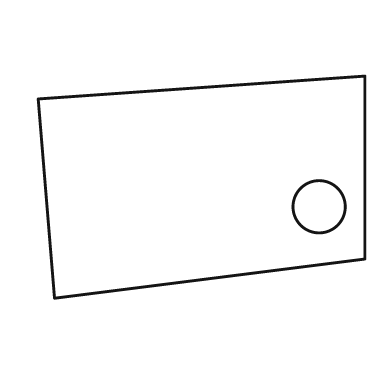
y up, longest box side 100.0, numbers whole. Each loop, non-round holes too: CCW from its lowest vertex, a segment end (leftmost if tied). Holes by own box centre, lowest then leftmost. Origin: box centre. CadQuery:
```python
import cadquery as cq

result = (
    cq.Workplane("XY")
    .moveTo(-45.0, -34.0)
    .lineTo(50.0, -22.0)
    .lineTo(50.0, 34.0)
    .lineTo(-50.0, 27.0)
    .close()
    .moveTo(36.0, -6.0)
    .circle(8.0)
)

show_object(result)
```